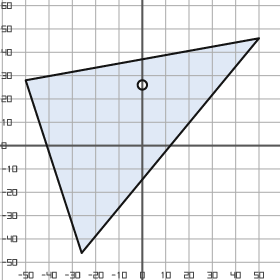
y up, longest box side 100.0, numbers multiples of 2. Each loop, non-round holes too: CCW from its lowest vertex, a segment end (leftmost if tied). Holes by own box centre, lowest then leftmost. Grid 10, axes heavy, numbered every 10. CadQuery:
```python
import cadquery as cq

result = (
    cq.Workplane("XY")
    .moveTo(-26.0, -46.0)
    .lineTo(50.0, 46.0)
    .lineTo(-50.0, 28.0)
    .close()
    .moveTo(0.0, 26.0)
    .circle(2.0)
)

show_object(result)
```